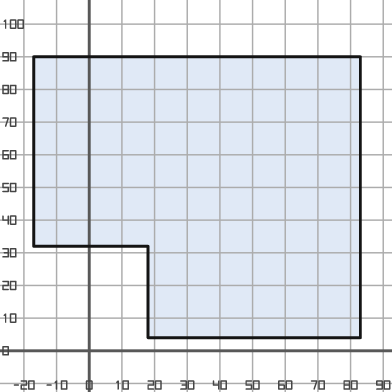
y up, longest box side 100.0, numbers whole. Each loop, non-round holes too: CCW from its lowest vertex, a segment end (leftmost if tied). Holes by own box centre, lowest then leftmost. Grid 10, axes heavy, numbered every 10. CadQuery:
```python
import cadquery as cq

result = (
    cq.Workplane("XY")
    .moveTo(18.0, 4.0)
    .lineTo(83.0, 4.0)
    .lineTo(83.0, 90.0)
    .lineTo(-17.0, 90.0)
    .lineTo(-17.0, 32.0)
    .lineTo(18.0, 32.0)
    .close()
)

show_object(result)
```